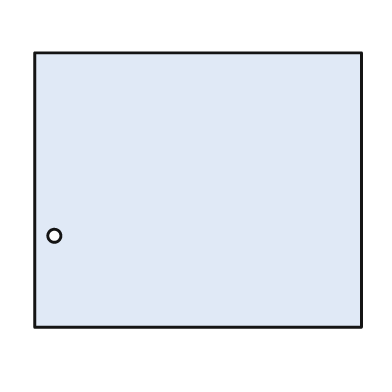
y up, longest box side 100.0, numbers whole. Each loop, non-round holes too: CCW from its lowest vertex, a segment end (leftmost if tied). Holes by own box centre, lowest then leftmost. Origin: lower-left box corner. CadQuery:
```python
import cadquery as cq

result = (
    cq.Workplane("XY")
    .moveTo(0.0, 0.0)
    .lineTo(100.0, 0.0)
    .lineTo(100.0, 84.0)
    .lineTo(0.0, 84.0)
    .close()
    .moveTo(6.0, 28.0)
    .circle(2.0)
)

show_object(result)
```